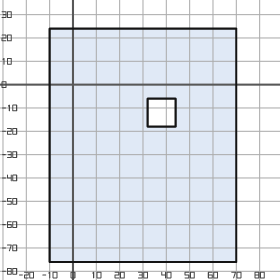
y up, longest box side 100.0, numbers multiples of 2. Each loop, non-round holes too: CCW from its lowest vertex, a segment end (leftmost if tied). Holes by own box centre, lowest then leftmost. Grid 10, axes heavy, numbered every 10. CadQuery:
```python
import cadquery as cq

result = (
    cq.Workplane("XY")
    .moveTo(-10.0, -76.0)
    .lineTo(70.0, -76.0)
    .lineTo(70.0, 24.0)
    .lineTo(-10.0, 24.0)
    .close()
    .moveTo(32.0, -18.0)
    .lineTo(44.0, -18.0)
    .lineTo(44.0, -6.0)
    .lineTo(32.0, -6.0)
    .close()
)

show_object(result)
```